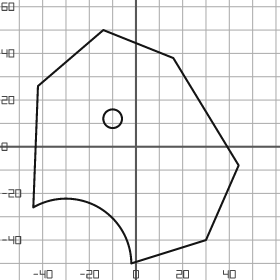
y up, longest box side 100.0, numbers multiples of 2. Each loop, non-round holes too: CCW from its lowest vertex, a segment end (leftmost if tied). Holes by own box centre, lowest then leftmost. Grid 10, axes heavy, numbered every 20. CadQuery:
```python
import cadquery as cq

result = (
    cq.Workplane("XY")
    .moveTo(-2.0, -50.0)
    .lineTo(30.0, -40.0)
    .lineTo(44.0, -8.0)
    .lineTo(16.0, 38.0)
    .lineTo(-14.0, 50.0)
    .lineTo(-42.0, 26.0)
    .lineTo(-44.0, -26.0)
    .threePointArc((-16.0, -26.0), (-2.0, -50.0))
    .close()
    .moveTo(-10.0, 12.0)
    .circle(4.0)
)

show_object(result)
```